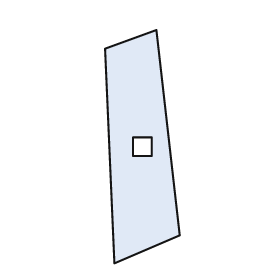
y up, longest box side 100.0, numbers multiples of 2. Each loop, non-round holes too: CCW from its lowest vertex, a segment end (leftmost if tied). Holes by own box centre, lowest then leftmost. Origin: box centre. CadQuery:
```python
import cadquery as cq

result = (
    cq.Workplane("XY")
    .moveTo(-12.0, -50.0)
    .lineTo(16.0, -38.0)
    .lineTo(6.0, 50.0)
    .lineTo(-16.0, 42.0)
    .close()
    .moveTo(-4.0, -4.0)
    .lineTo(4.0, -4.0)
    .lineTo(4.0, 4.0)
    .lineTo(-4.0, 4.0)
    .close()
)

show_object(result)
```